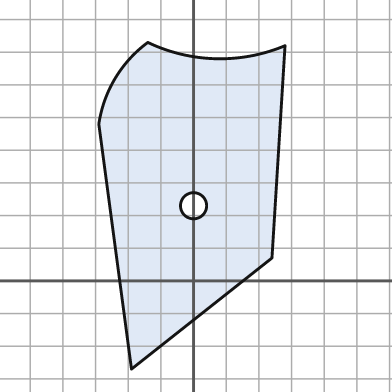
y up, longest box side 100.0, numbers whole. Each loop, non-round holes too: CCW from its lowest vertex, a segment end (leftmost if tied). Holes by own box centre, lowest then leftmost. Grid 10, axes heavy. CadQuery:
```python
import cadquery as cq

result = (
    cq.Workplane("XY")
    .moveTo(-19.0, -27.0)
    .lineTo(24.0, 7.0)
    .lineTo(28.0, 72.0)
    .threePointArc((7.0, 68.0), (-14.0, 73.0))
    .threePointArc((-24.0, 62.0), (-29.0, 48.0))
    .close()
    .moveTo(0.0, 23.0)
    .circle(4.0)
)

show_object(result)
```